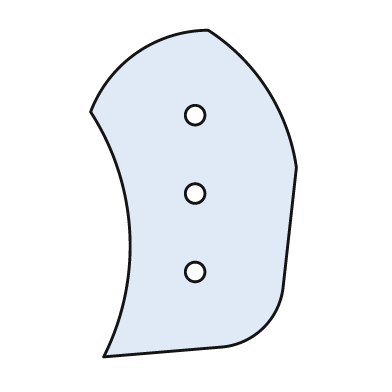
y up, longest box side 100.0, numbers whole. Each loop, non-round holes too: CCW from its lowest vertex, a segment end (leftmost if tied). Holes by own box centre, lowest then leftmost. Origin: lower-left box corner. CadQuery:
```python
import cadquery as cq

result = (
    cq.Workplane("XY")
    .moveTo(4.0, 0.0)
    .lineTo(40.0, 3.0)
    .threePointArc((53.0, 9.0), (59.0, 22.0))
    .lineTo(63.0, 58.0)
    .threePointArc((54.0, 82.0), (36.0, 100.0))
    .threePointArc((14.0, 93.0), (0.0, 75.0))
    .threePointArc((12.0, 38.0), (4.0, 0.0))
    .close()
    .moveTo(32.0, 26.0)
    .circle(3.0)
    .moveTo(32.0, 50.0)
    .circle(3.0)
    .moveTo(32.0, 74.0)
    .circle(3.0)
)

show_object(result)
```